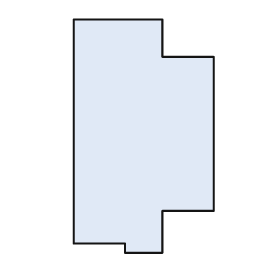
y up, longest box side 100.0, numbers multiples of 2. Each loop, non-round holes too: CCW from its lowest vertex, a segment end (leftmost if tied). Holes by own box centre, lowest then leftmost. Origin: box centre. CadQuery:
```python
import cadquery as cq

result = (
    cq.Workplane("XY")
    .moveTo(-8.0, -50.0)
    .lineTo(8.0, -50.0)
    .lineTo(8.0, -32.0)
    .lineTo(30.0, -32.0)
    .lineTo(30.0, 34.0)
    .lineTo(8.0, 34.0)
    .lineTo(8.0, 50.0)
    .lineTo(-30.0, 50.0)
    .lineTo(-30.0, -46.0)
    .lineTo(-8.0, -46.0)
    .close()
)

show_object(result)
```